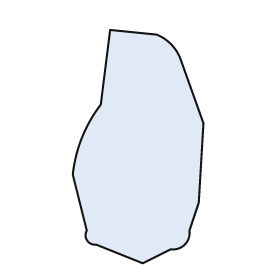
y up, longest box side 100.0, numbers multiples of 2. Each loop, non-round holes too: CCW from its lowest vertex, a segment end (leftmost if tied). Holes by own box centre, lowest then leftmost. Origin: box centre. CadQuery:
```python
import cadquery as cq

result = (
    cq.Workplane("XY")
    .moveTo(2.0, -50.0)
    .lineTo(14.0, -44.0)
    .threePointArc((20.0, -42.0), (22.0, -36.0))
    .lineTo(26.0, -24.0)
    .lineTo(28.0, 10.0)
    .lineTo(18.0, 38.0)
    .threePointArc((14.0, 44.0), (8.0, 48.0))
    .lineTo(-12.0, 50.0)
    .lineTo(-16.0, 18.0)
    .threePointArc((-24.0, 4.0), (-28.0, -12.0))
    .lineTo(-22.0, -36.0)
    .threePointArc((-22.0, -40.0), (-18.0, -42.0))
    .close()
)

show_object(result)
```